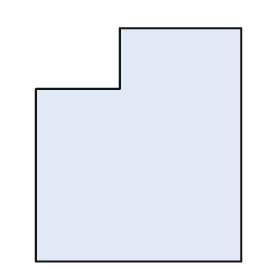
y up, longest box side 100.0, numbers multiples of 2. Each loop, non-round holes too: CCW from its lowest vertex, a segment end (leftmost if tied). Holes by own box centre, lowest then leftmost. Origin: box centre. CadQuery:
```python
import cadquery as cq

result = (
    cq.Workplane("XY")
    .moveTo(-44.0, -50.0)
    .lineTo(44.0, -50.0)
    .lineTo(44.0, 50.0)
    .lineTo(-8.0, 50.0)
    .lineTo(-8.0, 24.0)
    .lineTo(-44.0, 24.0)
    .close()
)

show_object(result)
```